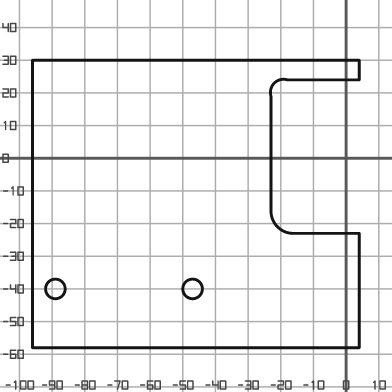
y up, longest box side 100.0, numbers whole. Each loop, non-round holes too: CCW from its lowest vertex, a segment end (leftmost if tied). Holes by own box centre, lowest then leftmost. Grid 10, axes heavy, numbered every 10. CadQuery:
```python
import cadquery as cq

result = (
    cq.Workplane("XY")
    .moveTo(-96.0, -58.0)
    .lineTo(4.0, -58.0)
    .lineTo(4.0, -23.0)
    .lineTo(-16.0, -23.0)
    .threePointArc((-21.0, -21.0), (-23.0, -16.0))
    .lineTo(-23.0, 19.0)
    .threePointArc((-22.0, 23.0), (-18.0, 24.0))
    .lineTo(4.0, 24.0)
    .lineTo(4.0, 30.0)
    .lineTo(-96.0, 30.0)
    .close()
    .moveTo(-89.0, -40.0)
    .circle(3.0)
    .moveTo(-47.0, -40.0)
    .circle(3.0)
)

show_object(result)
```